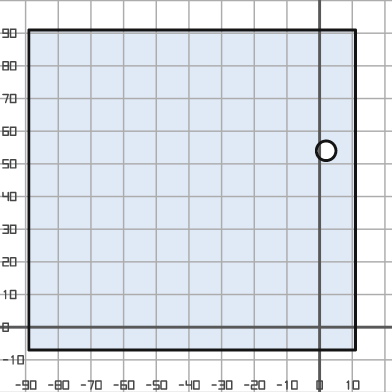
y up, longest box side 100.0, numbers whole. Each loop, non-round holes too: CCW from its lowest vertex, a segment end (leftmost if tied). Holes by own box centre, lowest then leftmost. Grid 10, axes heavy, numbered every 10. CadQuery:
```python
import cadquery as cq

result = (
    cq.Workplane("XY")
    .moveTo(-89.0, -7.0)
    .lineTo(11.0, -7.0)
    .lineTo(11.0, 91.0)
    .lineTo(-89.0, 91.0)
    .close()
    .moveTo(2.0, 54.0)
    .circle(3.0)
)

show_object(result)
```